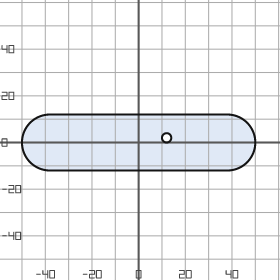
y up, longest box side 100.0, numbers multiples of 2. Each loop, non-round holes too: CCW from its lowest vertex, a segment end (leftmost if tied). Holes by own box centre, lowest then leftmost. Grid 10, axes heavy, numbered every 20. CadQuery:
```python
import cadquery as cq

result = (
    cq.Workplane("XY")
    .moveTo(-38.0, -12.0)
    .lineTo(38.0, -12.0)
    .threePointArc((50.0, 0.0), (38.0, 12.0))
    .lineTo(-38.0, 12.0)
    .threePointArc((-50.0, 0.0), (-38.0, -12.0))
    .close()
    .moveTo(12.0, 2.0)
    .circle(2.0)
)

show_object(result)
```